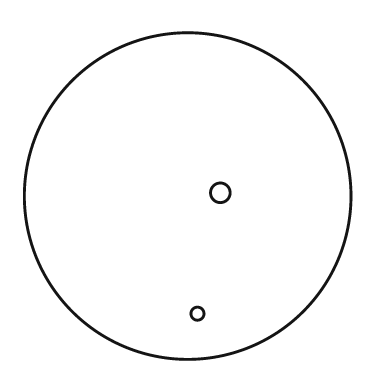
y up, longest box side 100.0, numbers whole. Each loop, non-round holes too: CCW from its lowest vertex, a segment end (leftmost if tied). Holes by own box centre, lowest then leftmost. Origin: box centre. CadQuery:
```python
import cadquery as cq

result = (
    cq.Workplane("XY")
    .moveTo(0.0, 0.0)
    .circle(50.0)
    .moveTo(3.0, -36.0)
    .circle(2.0)
    .moveTo(10.0, 1.0)
    .circle(3.0)
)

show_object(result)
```